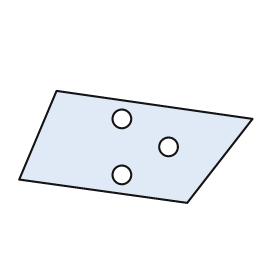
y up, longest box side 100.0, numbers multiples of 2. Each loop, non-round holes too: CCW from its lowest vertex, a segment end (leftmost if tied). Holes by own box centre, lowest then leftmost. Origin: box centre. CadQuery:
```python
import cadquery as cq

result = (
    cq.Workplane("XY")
    .moveTo(22.0, -24.0)
    .lineTo(50.0, 12.0)
    .lineTo(-34.0, 24.0)
    .lineTo(-50.0, -14.0)
    .close()
    .moveTo(-6.0, -12.0)
    .circle(4.0)
    .moveTo(14.0, 0.0)
    .circle(4.0)
    .moveTo(-6.0, 12.0)
    .circle(4.0)
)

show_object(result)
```